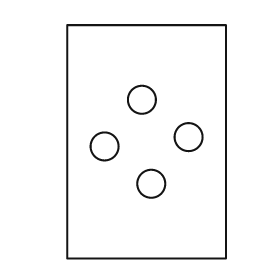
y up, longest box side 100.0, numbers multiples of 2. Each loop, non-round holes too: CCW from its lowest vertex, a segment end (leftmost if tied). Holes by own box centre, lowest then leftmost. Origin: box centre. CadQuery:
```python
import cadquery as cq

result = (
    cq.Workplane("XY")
    .moveTo(-34.0, -50.0)
    .lineTo(34.0, -50.0)
    .lineTo(34.0, 50.0)
    .lineTo(-34.0, 50.0)
    .close()
    .moveTo(2.0, -18.0)
    .circle(6.0)
    .moveTo(-18.0, -2.0)
    .circle(6.0)
    .moveTo(18.0, 2.0)
    .circle(6.0)
    .moveTo(-2.0, 18.0)
    .circle(6.0)
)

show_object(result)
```